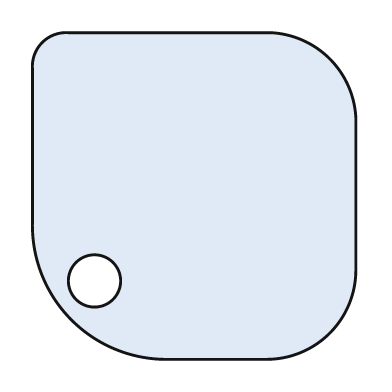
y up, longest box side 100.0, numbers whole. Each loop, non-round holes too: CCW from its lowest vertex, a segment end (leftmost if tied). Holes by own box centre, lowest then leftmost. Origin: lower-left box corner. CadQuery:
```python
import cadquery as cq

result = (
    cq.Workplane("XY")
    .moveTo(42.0, 0.0)
    .lineTo(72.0, 0.0)
    .threePointArc((91.0, 8.0), (99.0, 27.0))
    .lineTo(99.0, 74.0)
    .threePointArc((91.0, 92.0), (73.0, 100.0))
    .lineTo(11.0, 100.0)
    .threePointArc((3.0, 97.0), (0.0, 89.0))
    .lineTo(0.0, 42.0)
    .threePointArc((12.0, 12.0), (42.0, 0.0))
    .close()
    .moveTo(19.0, 24.0)
    .circle(8.0)
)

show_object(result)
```